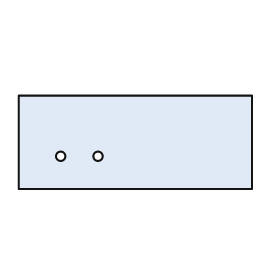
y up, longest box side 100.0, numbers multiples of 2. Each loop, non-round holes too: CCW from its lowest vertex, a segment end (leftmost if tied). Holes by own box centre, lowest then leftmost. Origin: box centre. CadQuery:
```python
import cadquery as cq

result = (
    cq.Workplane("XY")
    .moveTo(-50.0, -20.0)
    .lineTo(50.0, -20.0)
    .lineTo(50.0, 20.0)
    .lineTo(-50.0, 20.0)
    .close()
    .moveTo(-32.0, -6.0)
    .circle(2.0)
    .moveTo(-16.0, -6.0)
    .circle(2.0)
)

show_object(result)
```